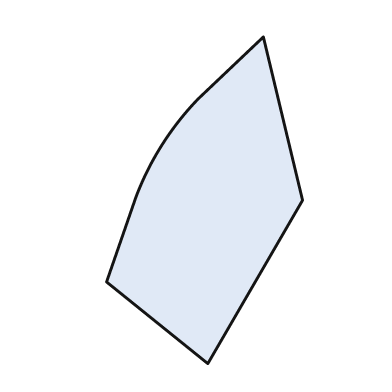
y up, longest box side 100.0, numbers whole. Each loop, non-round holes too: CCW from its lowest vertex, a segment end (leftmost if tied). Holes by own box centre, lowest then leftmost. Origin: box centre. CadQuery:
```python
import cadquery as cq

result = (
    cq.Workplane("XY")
    .moveTo(1.0, -50.0)
    .lineTo(30.0, 0.0)
    .lineTo(18.0, 50.0)
    .lineTo(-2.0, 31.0)
    .threePointArc((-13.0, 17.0), (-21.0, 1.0))
    .lineTo(-30.0, -25.0)
    .close()
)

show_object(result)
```